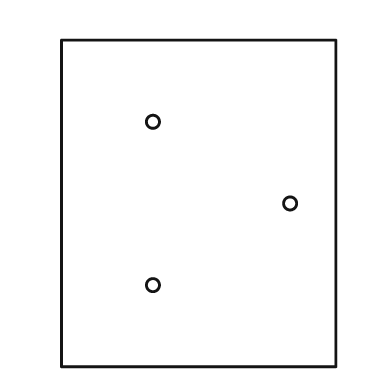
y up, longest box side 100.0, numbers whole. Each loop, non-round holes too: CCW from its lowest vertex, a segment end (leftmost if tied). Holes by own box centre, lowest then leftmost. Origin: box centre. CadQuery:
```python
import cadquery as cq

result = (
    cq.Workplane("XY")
    .moveTo(-42.0, -50.0)
    .lineTo(42.0, -50.0)
    .lineTo(42.0, 50.0)
    .lineTo(-42.0, 50.0)
    .close()
    .moveTo(-14.0, -25.0)
    .circle(2.0)
    .moveTo(28.0, 0.0)
    .circle(2.0)
    .moveTo(-14.0, 25.0)
    .circle(2.0)
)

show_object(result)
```